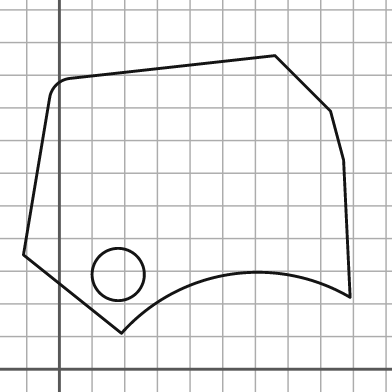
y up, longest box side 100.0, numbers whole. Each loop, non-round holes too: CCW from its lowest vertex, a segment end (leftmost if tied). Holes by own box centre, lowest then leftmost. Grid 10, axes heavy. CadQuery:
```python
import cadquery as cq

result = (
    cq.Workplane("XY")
    .moveTo(19.0, 11.0)
    .threePointArc((52.0, 29.0), (89.0, 22.0))
    .lineTo(87.0, 64.0)
    .lineTo(83.0, 79.0)
    .lineTo(66.0, 96.0)
    .lineTo(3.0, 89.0)
    .threePointArc((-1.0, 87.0), (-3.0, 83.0))
    .lineTo(-11.0, 35.0)
    .close()
    .moveTo(18.0, 29.0)
    .circle(8.0)
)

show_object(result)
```